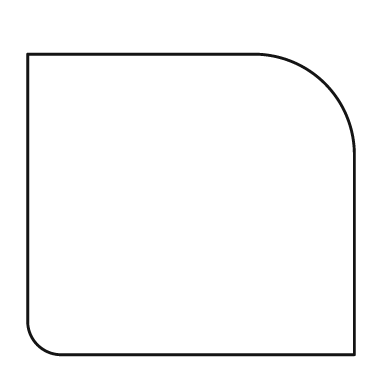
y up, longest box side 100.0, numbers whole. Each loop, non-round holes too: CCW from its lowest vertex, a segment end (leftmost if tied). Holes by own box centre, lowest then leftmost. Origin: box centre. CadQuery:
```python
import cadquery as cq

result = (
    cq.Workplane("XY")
    .moveTo(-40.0, -46.0)
    .lineTo(50.0, -46.0)
    .lineTo(50.0, 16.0)
    .threePointArc((41.0, 37.0), (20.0, 46.0))
    .lineTo(-50.0, 46.0)
    .lineTo(-50.0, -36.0)
    .threePointArc((-47.0, -43.0), (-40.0, -46.0))
    .close()
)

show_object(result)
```